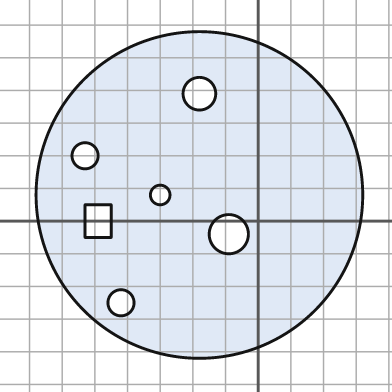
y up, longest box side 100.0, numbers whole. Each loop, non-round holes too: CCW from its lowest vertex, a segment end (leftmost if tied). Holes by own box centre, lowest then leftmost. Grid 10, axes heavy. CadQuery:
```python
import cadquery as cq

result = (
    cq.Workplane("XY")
    .moveTo(-18.0, 8.0)
    .circle(50.0)
    .moveTo(-42.0, -25.0)
    .circle(4.0)
    .moveTo(-9.0, -4.0)
    .circle(6.0)
    .moveTo(-53.0, -5.0)
    .lineTo(-45.0, -5.0)
    .lineTo(-45.0, 5.0)
    .lineTo(-53.0, 5.0)
    .close()
    .moveTo(-30.0, 8.0)
    .circle(3.0)
    .moveTo(-53.0, 20.0)
    .circle(4.0)
    .moveTo(-18.0, 39.0)
    .circle(5.0)
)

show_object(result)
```